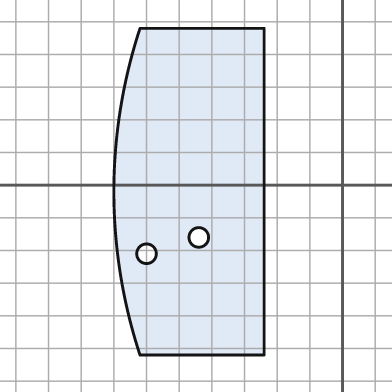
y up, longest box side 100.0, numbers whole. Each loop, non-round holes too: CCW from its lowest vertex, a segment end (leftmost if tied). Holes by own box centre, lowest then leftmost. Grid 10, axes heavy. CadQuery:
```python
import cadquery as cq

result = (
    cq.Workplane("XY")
    .moveTo(-62.0, -52.0)
    .lineTo(-24.0, -52.0)
    .lineTo(-24.0, 48.0)
    .lineTo(-62.0, 48.0)
    .threePointArc((-70.0, -2.0), (-62.0, -52.0))
    .close()
    .moveTo(-60.0, -21.0)
    .circle(3.0)
    .moveTo(-44.0, -16.0)
    .circle(3.0)
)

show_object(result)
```